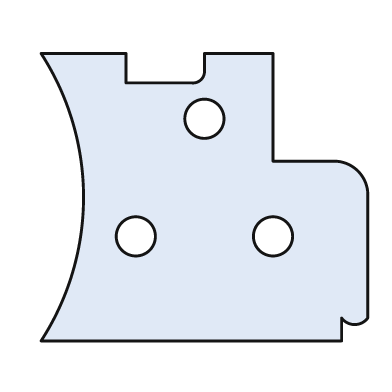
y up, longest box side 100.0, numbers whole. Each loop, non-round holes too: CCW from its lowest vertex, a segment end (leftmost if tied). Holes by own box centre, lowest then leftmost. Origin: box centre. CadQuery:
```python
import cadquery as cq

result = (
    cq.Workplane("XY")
    .moveTo(-50.0, -44.0)
    .lineTo(42.0, -44.0)
    .lineTo(42.0, -37.0)
    .threePointArc((46.0, -39.0), (50.0, -37.0))
    .lineTo(50.0, 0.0)
    .threePointArc((47.0, 8.0), (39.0, 11.0))
    .lineTo(21.0, 11.0)
    .lineTo(21.0, 44.0)
    .lineTo(0.0, 44.0)
    .lineTo(0.0, 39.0)
    .threePointArc((-1.0, 36.0), (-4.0, 35.0))
    .lineTo(-24.0, 35.0)
    .lineTo(-24.0, 44.0)
    .lineTo(-50.0, 44.0)
    .threePointArc((-37.0, 0.0), (-50.0, -44.0))
    .close()
    .moveTo(-21.0, -12.0)
    .circle(6.0)
    .moveTo(21.0, -12.0)
    .circle(6.0)
    .moveTo(0.0, 24.0)
    .circle(6.0)
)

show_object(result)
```